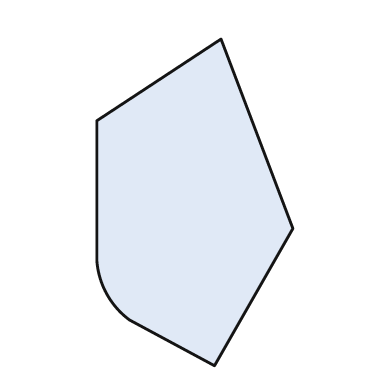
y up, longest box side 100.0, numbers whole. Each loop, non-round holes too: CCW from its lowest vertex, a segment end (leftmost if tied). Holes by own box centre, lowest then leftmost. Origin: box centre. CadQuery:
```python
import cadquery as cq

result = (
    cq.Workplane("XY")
    .moveTo(6.0, -50.0)
    .lineTo(30.0, -8.0)
    .lineTo(8.0, 50.0)
    .lineTo(-30.0, 25.0)
    .lineTo(-30.0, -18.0)
    .threePointArc((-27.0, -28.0), (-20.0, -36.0))
    .close()
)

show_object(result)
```